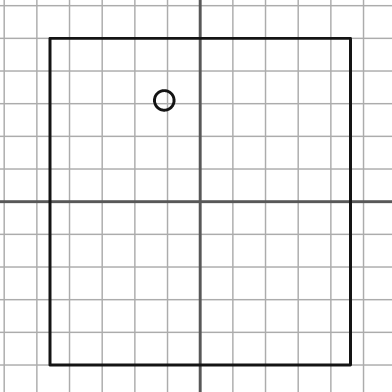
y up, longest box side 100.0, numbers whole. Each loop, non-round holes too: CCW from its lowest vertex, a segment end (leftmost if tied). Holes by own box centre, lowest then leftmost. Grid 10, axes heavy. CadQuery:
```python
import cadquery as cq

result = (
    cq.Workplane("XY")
    .moveTo(-46.0, -50.0)
    .lineTo(46.0, -50.0)
    .lineTo(46.0, 50.0)
    .lineTo(-46.0, 50.0)
    .close()
    .moveTo(-11.0, 31.0)
    .circle(3.0)
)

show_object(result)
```